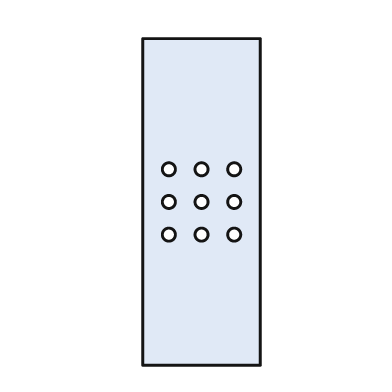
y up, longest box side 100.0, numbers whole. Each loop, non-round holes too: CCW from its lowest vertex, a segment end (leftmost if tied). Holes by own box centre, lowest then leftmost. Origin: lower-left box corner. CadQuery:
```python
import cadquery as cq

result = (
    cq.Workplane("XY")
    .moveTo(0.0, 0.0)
    .lineTo(36.0, 0.0)
    .lineTo(36.0, 100.0)
    .lineTo(0.0, 100.0)
    .close()
    .moveTo(8.0, 40.0)
    .circle(2.0)
    .moveTo(18.0, 40.0)
    .circle(2.0)
    .moveTo(28.0, 40.0)
    .circle(2.0)
    .moveTo(8.0, 50.0)
    .circle(2.0)
    .moveTo(18.0, 50.0)
    .circle(2.0)
    .moveTo(28.0, 50.0)
    .circle(2.0)
    .moveTo(8.0, 60.0)
    .circle(2.0)
    .moveTo(18.0, 60.0)
    .circle(2.0)
    .moveTo(28.0, 60.0)
    .circle(2.0)
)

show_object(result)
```